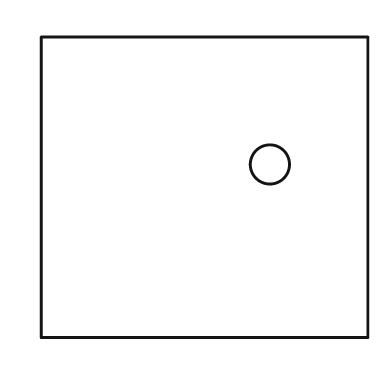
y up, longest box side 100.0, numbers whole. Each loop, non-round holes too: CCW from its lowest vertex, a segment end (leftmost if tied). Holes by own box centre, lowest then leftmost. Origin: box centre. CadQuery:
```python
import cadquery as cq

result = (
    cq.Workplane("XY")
    .moveTo(-50.0, -46.0)
    .lineTo(50.0, -46.0)
    .lineTo(50.0, 46.0)
    .lineTo(-50.0, 46.0)
    .close()
    .moveTo(20.0, 7.0)
    .circle(6.0)
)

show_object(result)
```